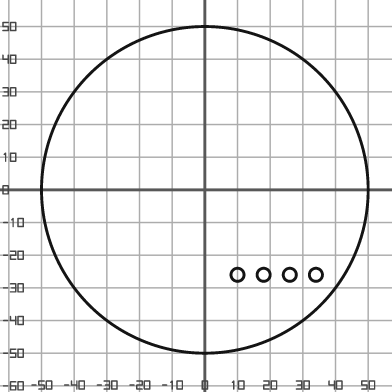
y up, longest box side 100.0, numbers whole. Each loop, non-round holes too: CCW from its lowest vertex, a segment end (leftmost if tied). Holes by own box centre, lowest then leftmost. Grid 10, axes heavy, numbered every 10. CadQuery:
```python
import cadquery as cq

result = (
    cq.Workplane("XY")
    .moveTo(0.0, 0.0)
    .circle(50.0)
    .moveTo(10.0, -26.0)
    .circle(2.0)
    .moveTo(18.0, -26.0)
    .circle(2.0)
    .moveTo(26.0, -26.0)
    .circle(2.0)
    .moveTo(34.0, -26.0)
    .circle(2.0)
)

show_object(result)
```